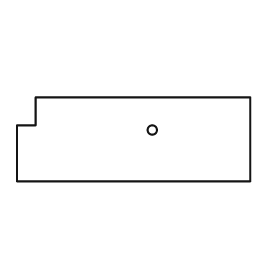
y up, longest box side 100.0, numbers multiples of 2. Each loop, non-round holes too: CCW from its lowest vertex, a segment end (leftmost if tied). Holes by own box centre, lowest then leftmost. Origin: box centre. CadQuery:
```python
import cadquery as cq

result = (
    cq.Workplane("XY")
    .moveTo(-50.0, -18.0)
    .lineTo(50.0, -18.0)
    .lineTo(50.0, 18.0)
    .lineTo(-42.0, 18.0)
    .lineTo(-42.0, 6.0)
    .lineTo(-50.0, 6.0)
    .close()
    .moveTo(8.0, 4.0)
    .circle(2.0)
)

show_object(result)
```